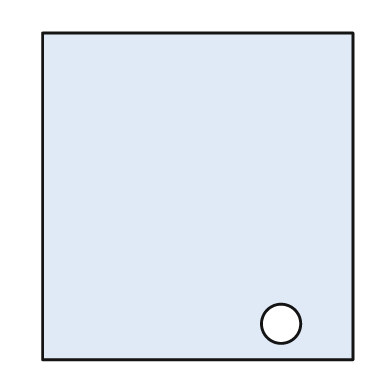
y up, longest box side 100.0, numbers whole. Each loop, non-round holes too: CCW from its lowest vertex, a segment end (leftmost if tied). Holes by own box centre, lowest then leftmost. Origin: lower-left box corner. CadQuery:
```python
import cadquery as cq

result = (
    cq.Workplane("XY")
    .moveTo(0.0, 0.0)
    .lineTo(95.0, 0.0)
    .lineTo(95.0, 100.0)
    .lineTo(0.0, 100.0)
    .close()
    .moveTo(73.0, 11.0)
    .circle(6.0)
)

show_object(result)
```